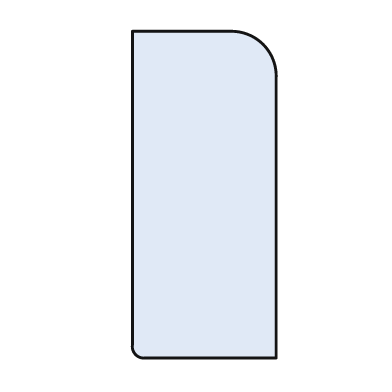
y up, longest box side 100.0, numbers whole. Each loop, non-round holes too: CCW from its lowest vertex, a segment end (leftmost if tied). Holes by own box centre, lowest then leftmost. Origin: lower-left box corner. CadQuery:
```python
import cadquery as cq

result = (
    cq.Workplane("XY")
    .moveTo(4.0, 0.0)
    .lineTo(44.0, 0.0)
    .lineTo(44.0, 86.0)
    .threePointArc((40.0, 96.0), (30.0, 100.0))
    .lineTo(0.0, 100.0)
    .lineTo(0.0, 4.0)
    .threePointArc((1.0, 1.0), (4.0, 0.0))
    .close()
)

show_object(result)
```